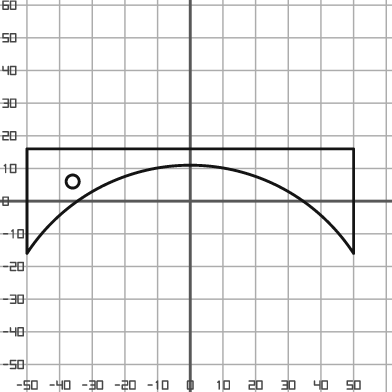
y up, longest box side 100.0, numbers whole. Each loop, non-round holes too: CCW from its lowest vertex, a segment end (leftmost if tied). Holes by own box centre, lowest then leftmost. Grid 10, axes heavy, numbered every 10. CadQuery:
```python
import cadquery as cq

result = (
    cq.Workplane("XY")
    .moveTo(-50.0, -16.0)
    .threePointArc((0.0, 11.0), (50.0, -16.0))
    .lineTo(50.0, 16.0)
    .lineTo(-50.0, 16.0)
    .close()
    .moveTo(-36.0, 6.0)
    .circle(2.0)
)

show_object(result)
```